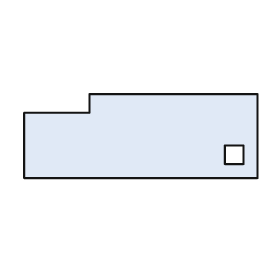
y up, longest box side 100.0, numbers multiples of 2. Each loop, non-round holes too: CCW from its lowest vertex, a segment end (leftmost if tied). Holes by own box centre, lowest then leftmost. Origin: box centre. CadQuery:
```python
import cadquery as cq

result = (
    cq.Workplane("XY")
    .moveTo(-50.0, -18.0)
    .lineTo(50.0, -18.0)
    .lineTo(50.0, 18.0)
    .lineTo(-22.0, 18.0)
    .lineTo(-22.0, 10.0)
    .lineTo(-50.0, 10.0)
    .close()
    .moveTo(36.0, -12.0)
    .lineTo(44.0, -12.0)
    .lineTo(44.0, -4.0)
    .lineTo(36.0, -4.0)
    .close()
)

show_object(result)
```